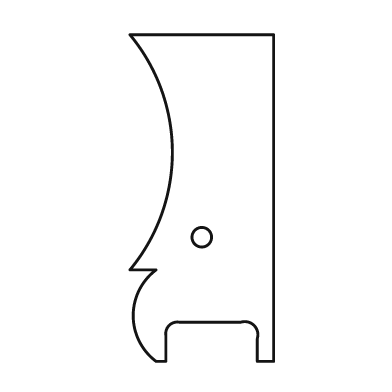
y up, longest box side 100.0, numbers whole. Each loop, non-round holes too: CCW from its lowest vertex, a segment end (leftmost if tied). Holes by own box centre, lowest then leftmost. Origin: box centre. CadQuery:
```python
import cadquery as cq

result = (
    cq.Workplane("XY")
    .moveTo(-14.0, -50.0)
    .lineTo(-11.0, -50.0)
    .lineTo(-11.0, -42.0)
    .threePointArc((-10.0, -39.0), (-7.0, -38.0))
    .lineTo(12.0, -38.0)
    .threePointArc((16.0, -39.0), (17.0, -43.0))
    .lineTo(17.0, -50.0)
    .lineTo(22.0, -50.0)
    .lineTo(22.0, 50.0)
    .lineTo(-22.0, 50.0)
    .threePointArc((-9.0, 14.0), (-22.0, -22.0))
    .lineTo(-14.0, -22.0)
    .threePointArc((-21.0, -36.0), (-14.0, -50.0))
    .close()
    .moveTo(0.0, -12.0)
    .circle(3.0)
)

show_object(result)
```